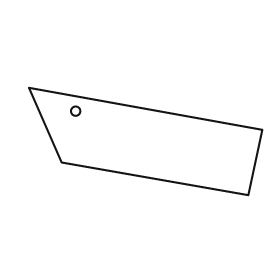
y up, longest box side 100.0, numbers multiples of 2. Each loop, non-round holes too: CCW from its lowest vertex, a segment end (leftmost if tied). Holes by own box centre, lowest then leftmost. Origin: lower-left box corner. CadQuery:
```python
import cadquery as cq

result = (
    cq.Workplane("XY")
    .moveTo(94.0, 0.0)
    .lineTo(100.0, 28.0)
    .lineTo(0.0, 46.0)
    .lineTo(14.0, 14.0)
    .close()
    .moveTo(20.0, 36.0)
    .circle(2.0)
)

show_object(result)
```